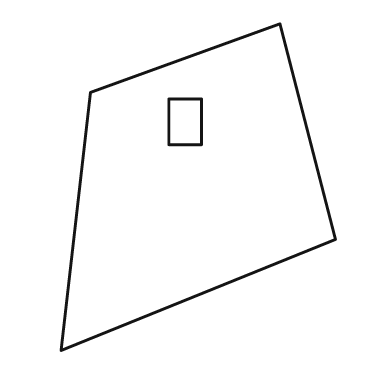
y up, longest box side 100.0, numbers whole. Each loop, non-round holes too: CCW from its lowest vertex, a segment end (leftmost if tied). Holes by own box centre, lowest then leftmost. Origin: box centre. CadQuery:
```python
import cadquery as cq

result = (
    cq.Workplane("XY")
    .moveTo(-42.0, -50.0)
    .lineTo(42.0, -16.0)
    .lineTo(25.0, 50.0)
    .lineTo(-33.0, 29.0)
    .close()
    .moveTo(-9.0, 13.0)
    .lineTo(1.0, 13.0)
    .lineTo(1.0, 27.0)
    .lineTo(-9.0, 27.0)
    .close()
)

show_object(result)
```